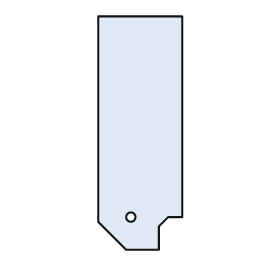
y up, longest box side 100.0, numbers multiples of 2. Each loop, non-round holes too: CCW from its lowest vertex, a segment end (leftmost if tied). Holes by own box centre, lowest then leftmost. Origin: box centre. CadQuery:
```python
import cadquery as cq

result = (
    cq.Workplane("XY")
    .moveTo(-6.0, -50.0)
    .lineTo(8.0, -50.0)
    .lineTo(8.0, -40.0)
    .lineTo(12.0, -36.0)
    .lineTo(18.0, -36.0)
    .lineTo(18.0, 50.0)
    .lineTo(-18.0, 50.0)
    .lineTo(-18.0, -38.0)
    .close()
    .moveTo(-4.0, -36.0)
    .circle(2.0)
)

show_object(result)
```